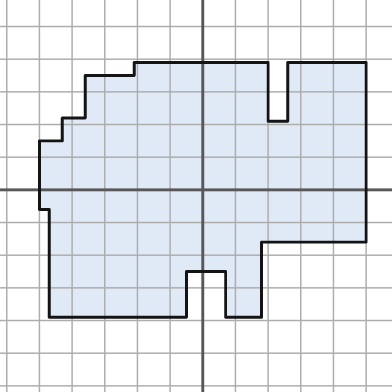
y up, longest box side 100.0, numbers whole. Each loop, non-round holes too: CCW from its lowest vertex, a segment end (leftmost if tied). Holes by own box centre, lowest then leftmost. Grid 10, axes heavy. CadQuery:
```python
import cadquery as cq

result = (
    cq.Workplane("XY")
    .moveTo(-47.0, -39.0)
    .lineTo(-5.0, -39.0)
    .lineTo(-5.0, -25.0)
    .lineTo(7.0, -25.0)
    .lineTo(7.0, -39.0)
    .lineTo(18.0, -39.0)
    .lineTo(18.0, -16.0)
    .lineTo(50.0, -16.0)
    .lineTo(50.0, 39.0)
    .lineTo(26.0, 39.0)
    .lineTo(26.0, 21.0)
    .lineTo(20.0, 21.0)
    .lineTo(20.0, 39.0)
    .lineTo(-21.0, 39.0)
    .lineTo(-21.0, 35.0)
    .lineTo(-36.0, 35.0)
    .lineTo(-36.0, 22.0)
    .lineTo(-43.0, 22.0)
    .lineTo(-43.0, 15.0)
    .lineTo(-50.0, 15.0)
    .lineTo(-50.0, -6.0)
    .lineTo(-47.0, -6.0)
    .close()
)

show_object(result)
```